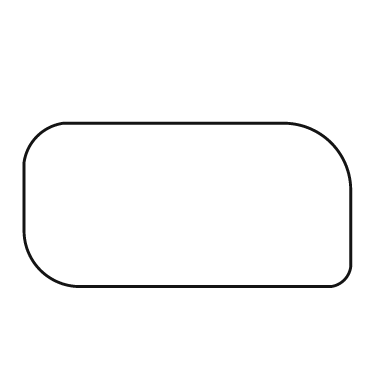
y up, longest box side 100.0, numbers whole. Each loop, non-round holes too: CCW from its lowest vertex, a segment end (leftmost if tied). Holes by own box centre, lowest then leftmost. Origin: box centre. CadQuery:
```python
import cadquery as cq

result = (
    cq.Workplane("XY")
    .moveTo(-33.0, -25.0)
    .lineTo(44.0, -25.0)
    .threePointArc((48.0, -23.0), (50.0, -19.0))
    .lineTo(50.0, 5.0)
    .threePointArc((44.0, 19.0), (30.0, 25.0))
    .lineTo(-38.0, 25.0)
    .threePointArc((-46.0, 21.0), (-50.0, 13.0))
    .lineTo(-50.0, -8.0)
    .threePointArc((-45.0, -20.0), (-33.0, -25.0))
    .close()
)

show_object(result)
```